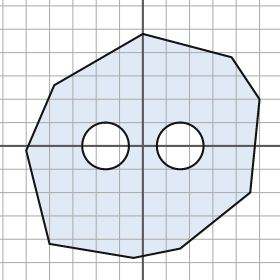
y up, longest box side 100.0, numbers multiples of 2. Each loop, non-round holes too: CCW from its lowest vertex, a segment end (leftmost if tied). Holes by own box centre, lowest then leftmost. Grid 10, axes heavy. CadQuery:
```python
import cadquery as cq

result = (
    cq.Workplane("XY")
    .moveTo(-4.0, -48.0)
    .lineTo(16.0, -44.0)
    .lineTo(46.0, -20.0)
    .lineTo(50.0, 20.0)
    .lineTo(38.0, 38.0)
    .lineTo(0.0, 48.0)
    .lineTo(-38.0, 26.0)
    .lineTo(-50.0, -2.0)
    .lineTo(-40.0, -42.0)
    .close()
    .moveTo(-16.0, 0.0)
    .circle(10.0)
    .moveTo(16.0, 0.0)
    .circle(10.0)
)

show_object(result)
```